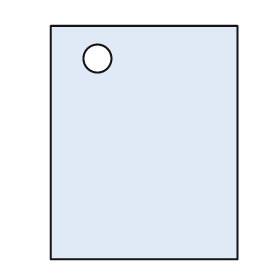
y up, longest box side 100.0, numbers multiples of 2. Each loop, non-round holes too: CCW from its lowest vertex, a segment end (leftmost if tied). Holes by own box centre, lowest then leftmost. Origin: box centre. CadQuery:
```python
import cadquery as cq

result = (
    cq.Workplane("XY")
    .moveTo(-40.0, -50.0)
    .lineTo(40.0, -50.0)
    .lineTo(40.0, 50.0)
    .lineTo(-40.0, 50.0)
    .close()
    .moveTo(-20.0, 36.0)
    .circle(6.0)
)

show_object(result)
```